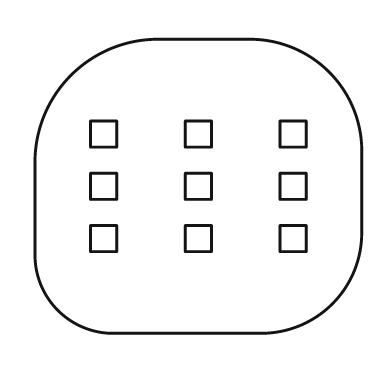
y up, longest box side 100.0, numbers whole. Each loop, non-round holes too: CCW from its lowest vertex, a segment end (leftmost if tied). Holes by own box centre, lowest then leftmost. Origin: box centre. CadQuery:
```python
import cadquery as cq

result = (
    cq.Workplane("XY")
    .moveTo(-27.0, -45.0)
    .lineTo(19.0, -45.0)
    .threePointArc((41.0, -36.0), (50.0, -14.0))
    .lineTo(50.0, 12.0)
    .threePointArc((40.0, 35.0), (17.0, 45.0))
    .lineTo(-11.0, 45.0)
    .threePointArc((-39.0, 34.0), (-50.0, 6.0))
    .lineTo(-50.0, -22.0)
    .threePointArc((-43.0, -38.0), (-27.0, -45.0))
    .close()
    .moveTo(-33.0, -20.0)
    .lineTo(-25.0, -20.0)
    .lineTo(-25.0, -12.0)
    .lineTo(-33.0, -12.0)
    .close()
    .moveTo(-4.0, -20.0)
    .lineTo(4.0, -20.0)
    .lineTo(4.0, -12.0)
    .lineTo(-4.0, -12.0)
    .close()
    .moveTo(25.0, -20.0)
    .lineTo(33.0, -20.0)
    .lineTo(33.0, -12.0)
    .lineTo(25.0, -12.0)
    .close()
    .moveTo(-33.0, -4.0)
    .lineTo(-25.0, -4.0)
    .lineTo(-25.0, 4.0)
    .lineTo(-33.0, 4.0)
    .close()
    .moveTo(-4.0, -4.0)
    .lineTo(4.0, -4.0)
    .lineTo(4.0, 4.0)
    .lineTo(-4.0, 4.0)
    .close()
    .moveTo(25.0, -4.0)
    .lineTo(33.0, -4.0)
    .lineTo(33.0, 4.0)
    .lineTo(25.0, 4.0)
    .close()
    .moveTo(-33.0, 12.0)
    .lineTo(-25.0, 12.0)
    .lineTo(-25.0, 20.0)
    .lineTo(-33.0, 20.0)
    .close()
    .moveTo(-4.0, 12.0)
    .lineTo(4.0, 12.0)
    .lineTo(4.0, 20.0)
    .lineTo(-4.0, 20.0)
    .close()
    .moveTo(25.0, 12.0)
    .lineTo(33.0, 12.0)
    .lineTo(33.0, 20.0)
    .lineTo(25.0, 20.0)
    .close()
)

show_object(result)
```